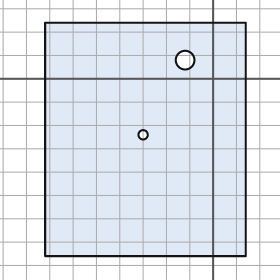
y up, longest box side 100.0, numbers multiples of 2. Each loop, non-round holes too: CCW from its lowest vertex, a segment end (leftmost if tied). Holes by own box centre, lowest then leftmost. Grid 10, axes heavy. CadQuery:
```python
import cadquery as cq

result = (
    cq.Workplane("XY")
    .moveTo(-72.0, -76.0)
    .lineTo(14.0, -76.0)
    .lineTo(14.0, 24.0)
    .lineTo(-72.0, 24.0)
    .close()
    .moveTo(-30.0, -24.0)
    .circle(2.0)
    .moveTo(-12.0, 8.0)
    .circle(4.0)
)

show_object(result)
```